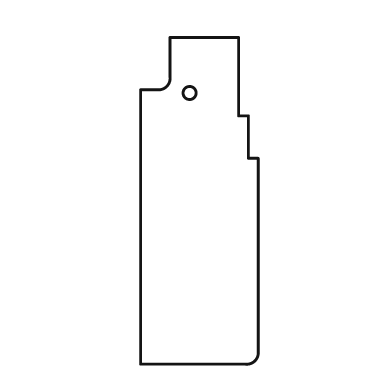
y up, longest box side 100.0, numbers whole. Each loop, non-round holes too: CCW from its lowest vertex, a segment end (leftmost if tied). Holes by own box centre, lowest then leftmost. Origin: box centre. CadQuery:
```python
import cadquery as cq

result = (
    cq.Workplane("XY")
    .moveTo(-18.0, -50.0)
    .lineTo(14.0, -50.0)
    .threePointArc((17.0, -49.0), (18.0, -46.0))
    .lineTo(18.0, 13.0)
    .lineTo(15.0, 13.0)
    .lineTo(15.0, 26.0)
    .lineTo(12.0, 26.0)
    .lineTo(12.0, 50.0)
    .lineTo(-9.0, 50.0)
    .lineTo(-9.0, 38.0)
    .threePointArc((-10.0, 35.0), (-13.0, 34.0))
    .lineTo(-18.0, 34.0)
    .close()
    .moveTo(-3.0, 33.0)
    .circle(2.0)
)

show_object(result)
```